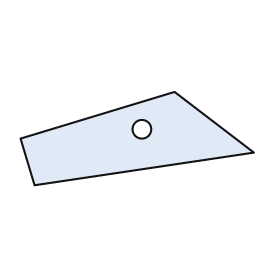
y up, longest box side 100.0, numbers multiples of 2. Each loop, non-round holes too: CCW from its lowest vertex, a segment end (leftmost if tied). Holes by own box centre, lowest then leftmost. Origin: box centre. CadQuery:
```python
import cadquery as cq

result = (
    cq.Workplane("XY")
    .moveTo(-44.0, -20.0)
    .lineTo(50.0, -6.0)
    .lineTo(16.0, 20.0)
    .lineTo(-50.0, 0.0)
    .close()
    .moveTo(2.0, 4.0)
    .circle(4.0)
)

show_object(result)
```